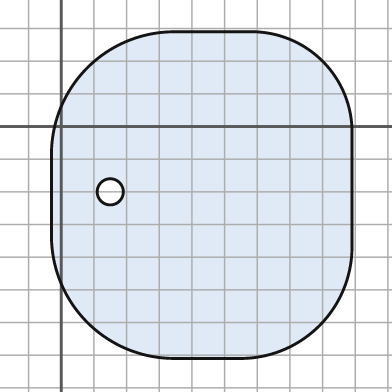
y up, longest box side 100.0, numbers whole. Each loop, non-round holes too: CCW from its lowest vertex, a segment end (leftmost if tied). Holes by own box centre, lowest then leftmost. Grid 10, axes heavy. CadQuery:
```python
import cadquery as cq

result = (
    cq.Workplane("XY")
    .moveTo(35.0, -71.0)
    .lineTo(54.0, -71.0)
    .threePointArc((79.0, -61.0), (89.0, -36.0))
    .lineTo(89.0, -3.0)
    .threePointArc((80.0, 20.0), (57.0, 29.0))
    .lineTo(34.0, 29.0)
    .threePointArc((8.0, 18.0), (-3.0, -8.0))
    .lineTo(-3.0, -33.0)
    .threePointArc((8.0, -60.0), (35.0, -71.0))
    .close()
    .moveTo(15.0, -20.0)
    .circle(4.0)
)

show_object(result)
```